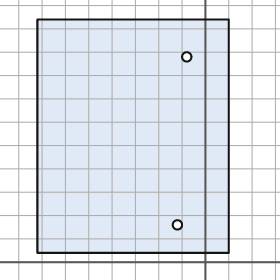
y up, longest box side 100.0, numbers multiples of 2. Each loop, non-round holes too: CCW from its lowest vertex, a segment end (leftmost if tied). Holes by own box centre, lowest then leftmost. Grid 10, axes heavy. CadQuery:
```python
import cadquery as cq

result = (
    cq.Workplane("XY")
    .moveTo(-72.0, 4.0)
    .lineTo(10.0, 4.0)
    .lineTo(10.0, 104.0)
    .lineTo(-72.0, 104.0)
    .close()
    .moveTo(-12.0, 16.0)
    .circle(2.0)
    .moveTo(-8.0, 88.0)
    .circle(2.0)
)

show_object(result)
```